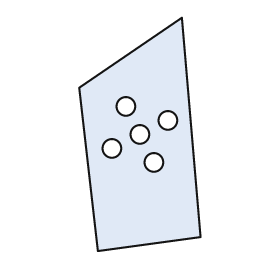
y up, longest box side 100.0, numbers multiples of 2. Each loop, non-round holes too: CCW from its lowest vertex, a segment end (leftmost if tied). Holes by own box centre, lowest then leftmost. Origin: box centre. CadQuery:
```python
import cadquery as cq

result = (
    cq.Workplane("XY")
    .moveTo(-18.0, -50.0)
    .lineTo(26.0, -44.0)
    .lineTo(18.0, 50.0)
    .lineTo(-26.0, 20.0)
    .close()
    .moveTo(6.0, -12.0)
    .circle(4.0)
    .moveTo(-12.0, -6.0)
    .circle(4.0)
    .moveTo(0.0, 0.0)
    .circle(4.0)
    .moveTo(12.0, 6.0)
    .circle(4.0)
    .moveTo(-6.0, 12.0)
    .circle(4.0)
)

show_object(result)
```